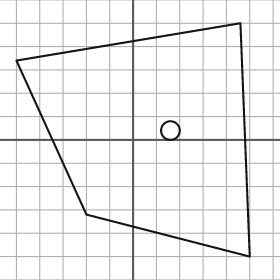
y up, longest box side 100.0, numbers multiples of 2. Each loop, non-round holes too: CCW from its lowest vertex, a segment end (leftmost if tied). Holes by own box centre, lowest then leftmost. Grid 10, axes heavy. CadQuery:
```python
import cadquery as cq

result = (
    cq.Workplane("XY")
    .moveTo(50.0, -50.0)
    .lineTo(46.0, 50.0)
    .lineTo(-50.0, 34.0)
    .lineTo(-20.0, -32.0)
    .close()
    .moveTo(16.0, 4.0)
    .circle(4.0)
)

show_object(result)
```